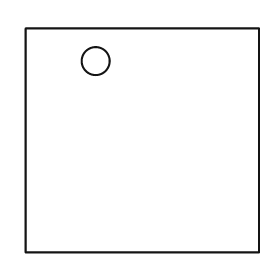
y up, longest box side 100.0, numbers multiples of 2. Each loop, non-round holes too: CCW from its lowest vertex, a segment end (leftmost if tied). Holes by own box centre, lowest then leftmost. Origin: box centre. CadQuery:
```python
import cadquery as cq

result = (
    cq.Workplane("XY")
    .moveTo(-50.0, -48.0)
    .lineTo(50.0, -48.0)
    .lineTo(50.0, 48.0)
    .lineTo(-50.0, 48.0)
    .close()
    .moveTo(-20.0, 34.0)
    .circle(6.0)
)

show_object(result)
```